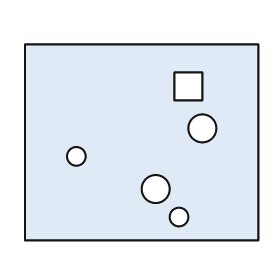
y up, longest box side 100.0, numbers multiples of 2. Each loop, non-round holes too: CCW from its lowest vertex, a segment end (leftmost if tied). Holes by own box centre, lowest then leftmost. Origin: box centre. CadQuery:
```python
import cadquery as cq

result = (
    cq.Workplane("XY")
    .moveTo(-50.0, -42.0)
    .lineTo(50.0, -42.0)
    .lineTo(50.0, 42.0)
    .lineTo(-50.0, 42.0)
    .close()
    .moveTo(16.0, -32.0)
    .circle(4.0)
    .moveTo(6.0, -20.0)
    .circle(6.0)
    .moveTo(-28.0, -6.0)
    .circle(4.0)
    .moveTo(26.0, 6.0)
    .circle(6.0)
    .moveTo(14.0, 18.0)
    .lineTo(26.0, 18.0)
    .lineTo(26.0, 30.0)
    .lineTo(14.0, 30.0)
    .close()
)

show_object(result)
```